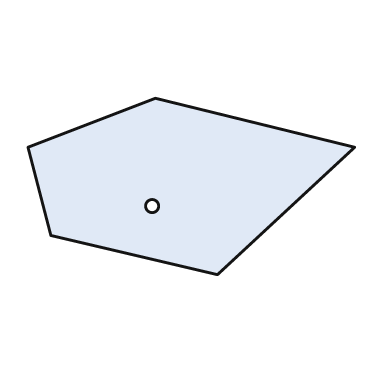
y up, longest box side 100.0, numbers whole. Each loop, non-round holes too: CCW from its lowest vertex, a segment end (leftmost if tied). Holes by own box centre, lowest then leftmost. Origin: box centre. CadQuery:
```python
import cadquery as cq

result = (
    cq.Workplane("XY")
    .moveTo(8.0, -27.0)
    .lineTo(50.0, 12.0)
    .lineTo(-11.0, 27.0)
    .lineTo(-50.0, 12.0)
    .lineTo(-43.0, -15.0)
    .close()
    .moveTo(-12.0, -6.0)
    .circle(2.0)
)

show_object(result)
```